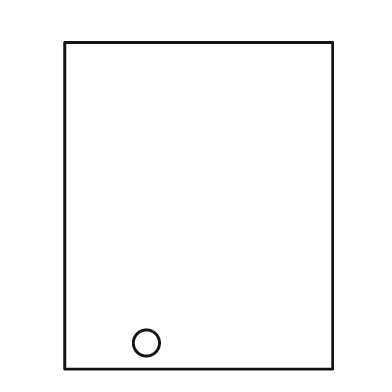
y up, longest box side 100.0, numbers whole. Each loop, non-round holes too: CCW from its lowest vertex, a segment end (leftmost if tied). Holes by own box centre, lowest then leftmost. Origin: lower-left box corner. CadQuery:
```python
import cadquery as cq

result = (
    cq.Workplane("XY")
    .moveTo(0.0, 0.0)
    .lineTo(82.0, 0.0)
    .lineTo(82.0, 100.0)
    .lineTo(0.0, 100.0)
    .close()
    .moveTo(25.0, 8.0)
    .circle(4.0)
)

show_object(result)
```